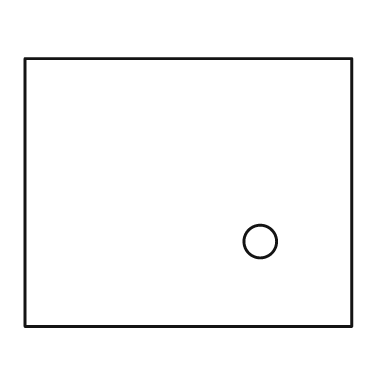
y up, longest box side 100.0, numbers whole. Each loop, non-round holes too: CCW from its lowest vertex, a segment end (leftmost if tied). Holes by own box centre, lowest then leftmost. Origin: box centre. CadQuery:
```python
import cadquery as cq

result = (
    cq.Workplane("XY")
    .moveTo(-50.0, -41.0)
    .lineTo(50.0, -41.0)
    .lineTo(50.0, 41.0)
    .lineTo(-50.0, 41.0)
    .close()
    .moveTo(22.0, -15.0)
    .circle(5.0)
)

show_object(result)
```